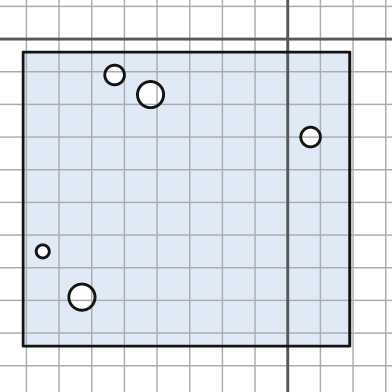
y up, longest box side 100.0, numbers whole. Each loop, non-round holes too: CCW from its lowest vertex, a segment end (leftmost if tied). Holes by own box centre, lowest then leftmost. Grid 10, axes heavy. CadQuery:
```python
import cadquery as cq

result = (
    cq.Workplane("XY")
    .moveTo(-81.0, -94.0)
    .lineTo(19.0, -94.0)
    .lineTo(19.0, -4.0)
    .lineTo(-81.0, -4.0)
    .close()
    .moveTo(-63.0, -79.0)
    .circle(4.0)
    .moveTo(-75.0, -65.0)
    .circle(2.0)
    .moveTo(7.0, -30.0)
    .circle(3.0)
    .moveTo(-42.0, -17.0)
    .circle(4.0)
    .moveTo(-53.0, -11.0)
    .circle(3.0)
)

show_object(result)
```